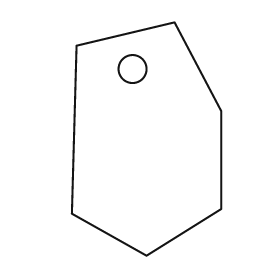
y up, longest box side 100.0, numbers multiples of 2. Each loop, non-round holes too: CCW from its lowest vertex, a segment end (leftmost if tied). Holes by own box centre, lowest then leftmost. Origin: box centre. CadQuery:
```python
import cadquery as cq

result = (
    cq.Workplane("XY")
    .moveTo(0.0, -50.0)
    .lineTo(32.0, -30.0)
    .lineTo(32.0, 12.0)
    .lineTo(12.0, 50.0)
    .lineTo(-30.0, 40.0)
    .lineTo(-32.0, -32.0)
    .close()
    .moveTo(-6.0, 30.0)
    .circle(6.0)
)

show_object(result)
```